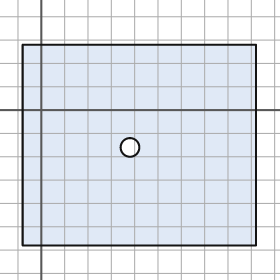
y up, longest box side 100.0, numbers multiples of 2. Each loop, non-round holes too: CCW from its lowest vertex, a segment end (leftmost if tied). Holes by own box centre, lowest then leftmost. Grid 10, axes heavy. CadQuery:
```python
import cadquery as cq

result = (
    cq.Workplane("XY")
    .moveTo(-8.0, -58.0)
    .lineTo(92.0, -58.0)
    .lineTo(92.0, 28.0)
    .lineTo(-8.0, 28.0)
    .close()
    .moveTo(38.0, -16.0)
    .circle(4.0)
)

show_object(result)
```